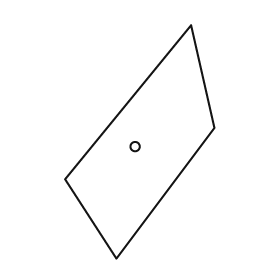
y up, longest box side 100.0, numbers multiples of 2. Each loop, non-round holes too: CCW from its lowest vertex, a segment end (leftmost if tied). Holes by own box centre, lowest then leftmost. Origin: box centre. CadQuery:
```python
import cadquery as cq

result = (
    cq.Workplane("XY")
    .moveTo(-10.0, -50.0)
    .lineTo(32.0, 6.0)
    .lineTo(22.0, 50.0)
    .lineTo(-32.0, -16.0)
    .close()
    .moveTo(-2.0, -2.0)
    .circle(2.0)
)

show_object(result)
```